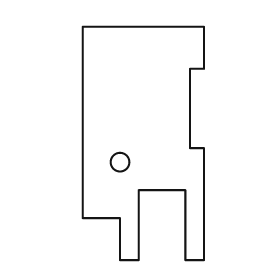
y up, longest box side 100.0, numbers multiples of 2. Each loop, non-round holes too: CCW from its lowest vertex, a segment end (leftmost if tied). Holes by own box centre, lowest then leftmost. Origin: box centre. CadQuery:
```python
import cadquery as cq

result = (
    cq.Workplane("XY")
    .moveTo(-10.0, -50.0)
    .lineTo(-2.0, -50.0)
    .lineTo(-2.0, -20.0)
    .lineTo(18.0, -20.0)
    .lineTo(18.0, -50.0)
    .lineTo(26.0, -50.0)
    .lineTo(26.0, -2.0)
    .lineTo(20.0, -2.0)
    .lineTo(20.0, 32.0)
    .lineTo(26.0, 32.0)
    .lineTo(26.0, 50.0)
    .lineTo(-26.0, 50.0)
    .lineTo(-26.0, -32.0)
    .lineTo(-10.0, -32.0)
    .close()
    .moveTo(-10.0, -8.0)
    .circle(4.0)
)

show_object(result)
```